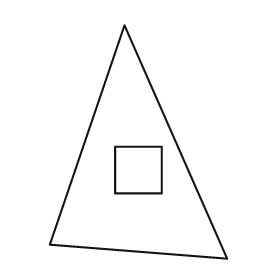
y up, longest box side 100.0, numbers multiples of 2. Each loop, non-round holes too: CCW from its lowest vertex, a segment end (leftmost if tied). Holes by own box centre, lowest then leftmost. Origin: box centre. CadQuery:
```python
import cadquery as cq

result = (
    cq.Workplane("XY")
    .moveTo(38.0, -50.0)
    .lineTo(-6.0, 50.0)
    .lineTo(-38.0, -44.0)
    .close()
    .moveTo(-10.0, -22.0)
    .lineTo(10.0, -22.0)
    .lineTo(10.0, -2.0)
    .lineTo(-10.0, -2.0)
    .close()
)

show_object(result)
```